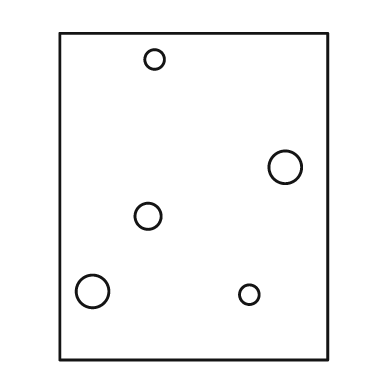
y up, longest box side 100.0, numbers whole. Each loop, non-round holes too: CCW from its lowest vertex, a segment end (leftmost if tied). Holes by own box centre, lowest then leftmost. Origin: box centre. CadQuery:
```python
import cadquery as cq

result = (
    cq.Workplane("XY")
    .moveTo(-41.0, -50.0)
    .lineTo(41.0, -50.0)
    .lineTo(41.0, 50.0)
    .lineTo(-41.0, 50.0)
    .close()
    .moveTo(17.0, -30.0)
    .circle(3.0)
    .moveTo(-31.0, -29.0)
    .circle(5.0)
    .moveTo(-14.0, -6.0)
    .circle(4.0)
    .moveTo(28.0, 9.0)
    .circle(5.0)
    .moveTo(-12.0, 42.0)
    .circle(3.0)
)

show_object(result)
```